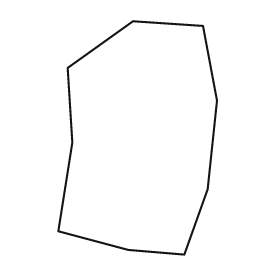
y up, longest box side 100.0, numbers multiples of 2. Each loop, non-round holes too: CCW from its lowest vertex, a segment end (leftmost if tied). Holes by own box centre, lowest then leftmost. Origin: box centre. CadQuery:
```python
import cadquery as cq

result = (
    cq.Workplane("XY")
    .moveTo(20.0, -50.0)
    .lineTo(30.0, -22.0)
    .lineTo(34.0, 16.0)
    .lineTo(28.0, 48.0)
    .lineTo(-2.0, 50.0)
    .lineTo(-30.0, 30.0)
    .lineTo(-28.0, -2.0)
    .lineTo(-34.0, -40.0)
    .lineTo(-4.0, -48.0)
    .close()
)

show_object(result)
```